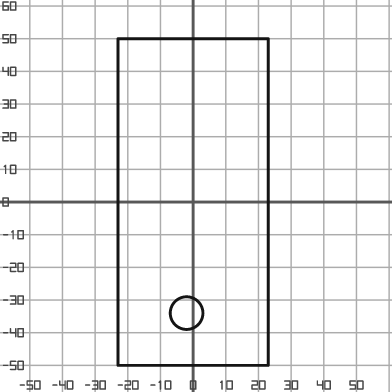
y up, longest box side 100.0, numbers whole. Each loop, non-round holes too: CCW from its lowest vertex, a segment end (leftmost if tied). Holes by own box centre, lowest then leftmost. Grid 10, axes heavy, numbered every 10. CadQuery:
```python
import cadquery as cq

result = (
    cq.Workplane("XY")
    .moveTo(-23.0, -50.0)
    .lineTo(23.0, -50.0)
    .lineTo(23.0, 50.0)
    .lineTo(-23.0, 50.0)
    .close()
    .moveTo(-2.0, -34.0)
    .circle(5.0)
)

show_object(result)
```